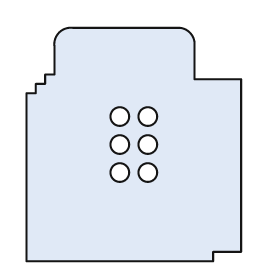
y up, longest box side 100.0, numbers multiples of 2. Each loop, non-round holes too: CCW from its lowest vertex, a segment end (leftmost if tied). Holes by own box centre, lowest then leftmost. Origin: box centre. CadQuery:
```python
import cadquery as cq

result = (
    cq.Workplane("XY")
    .moveTo(-46.0, -50.0)
    .lineTo(34.0, -50.0)
    .lineTo(34.0, -46.0)
    .lineTo(46.0, -46.0)
    .lineTo(46.0, 28.0)
    .lineTo(26.0, 28.0)
    .lineTo(26.0, 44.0)
    .threePointArc((24.0, 48.0), (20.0, 50.0))
    .lineTo(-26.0, 50.0)
    .threePointArc((-32.0, 48.0), (-34.0, 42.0))
    .lineTo(-34.0, 30.0)
    .lineTo(-38.0, 30.0)
    .lineTo(-38.0, 26.0)
    .lineTo(-42.0, 26.0)
    .lineTo(-42.0, 22.0)
    .lineTo(-46.0, 22.0)
    .close()
    .moveTo(-6.0, -12.0)
    .circle(4.0)
    .moveTo(6.0, -12.0)
    .circle(4.0)
    .moveTo(-6.0, 0.0)
    .circle(4.0)
    .moveTo(6.0, 0.0)
    .circle(4.0)
    .moveTo(-6.0, 12.0)
    .circle(4.0)
    .moveTo(6.0, 12.0)
    .circle(4.0)
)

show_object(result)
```